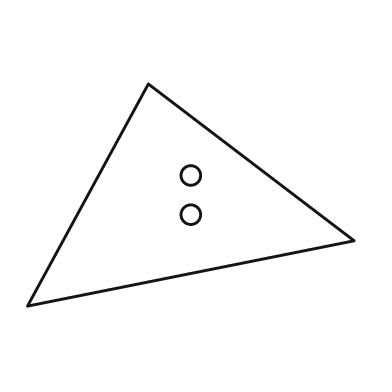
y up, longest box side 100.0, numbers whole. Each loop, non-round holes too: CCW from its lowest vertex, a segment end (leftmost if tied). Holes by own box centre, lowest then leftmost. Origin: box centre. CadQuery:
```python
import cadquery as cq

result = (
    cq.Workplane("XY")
    .moveTo(-50.0, -34.0)
    .lineTo(50.0, -14.0)
    .lineTo(-13.0, 34.0)
    .close()
    .moveTo(0.0, -6.0)
    .circle(3.0)
    .moveTo(0.0, 6.0)
    .circle(3.0)
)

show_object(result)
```